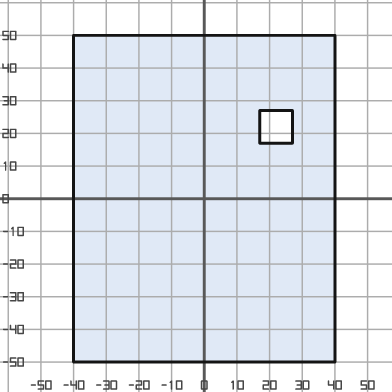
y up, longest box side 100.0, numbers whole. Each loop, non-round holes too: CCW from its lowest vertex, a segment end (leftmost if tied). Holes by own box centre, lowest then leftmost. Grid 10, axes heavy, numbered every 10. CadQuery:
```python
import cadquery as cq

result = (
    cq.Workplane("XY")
    .moveTo(-40.0, -50.0)
    .lineTo(40.0, -50.0)
    .lineTo(40.0, 50.0)
    .lineTo(-40.0, 50.0)
    .close()
    .moveTo(17.0, 17.0)
    .lineTo(27.0, 17.0)
    .lineTo(27.0, 27.0)
    .lineTo(17.0, 27.0)
    .close()
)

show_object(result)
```